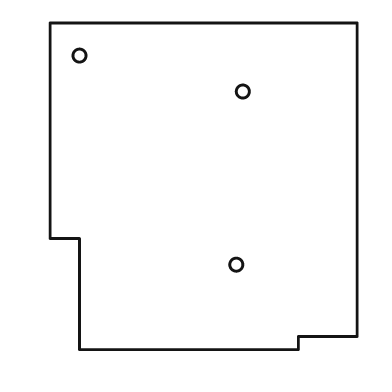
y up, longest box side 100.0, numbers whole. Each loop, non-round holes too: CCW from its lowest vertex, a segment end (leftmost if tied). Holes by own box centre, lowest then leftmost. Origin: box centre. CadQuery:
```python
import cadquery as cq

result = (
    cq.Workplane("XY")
    .moveTo(-38.0, -50.0)
    .lineTo(29.0, -50.0)
    .lineTo(29.0, -46.0)
    .lineTo(47.0, -46.0)
    .lineTo(47.0, 50.0)
    .lineTo(-47.0, 50.0)
    .lineTo(-47.0, -16.0)
    .lineTo(-38.0, -16.0)
    .close()
    .moveTo(10.0, -24.0)
    .circle(2.0)
    .moveTo(12.0, 29.0)
    .circle(2.0)
    .moveTo(-38.0, 40.0)
    .circle(2.0)
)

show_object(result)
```